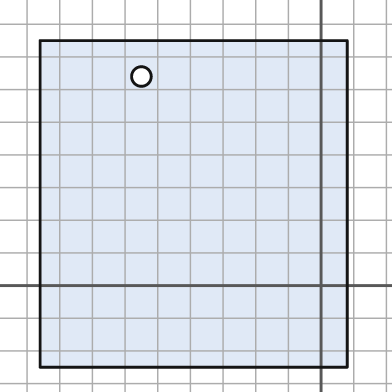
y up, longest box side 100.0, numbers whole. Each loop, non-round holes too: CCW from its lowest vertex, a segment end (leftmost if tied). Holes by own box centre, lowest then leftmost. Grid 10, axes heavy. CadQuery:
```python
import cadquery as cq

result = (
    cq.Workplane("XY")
    .moveTo(-86.0, -25.0)
    .lineTo(8.0, -25.0)
    .lineTo(8.0, 75.0)
    .lineTo(-86.0, 75.0)
    .close()
    .moveTo(-55.0, 64.0)
    .circle(3.0)
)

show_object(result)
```